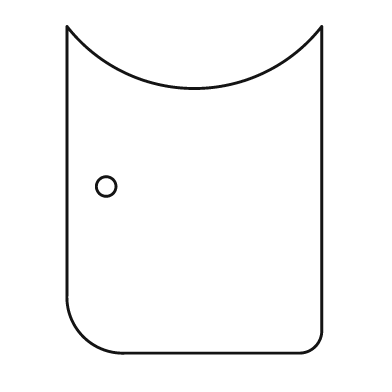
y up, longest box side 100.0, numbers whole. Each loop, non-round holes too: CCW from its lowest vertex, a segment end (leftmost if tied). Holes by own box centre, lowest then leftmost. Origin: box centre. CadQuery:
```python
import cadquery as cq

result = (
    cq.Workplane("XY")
    .moveTo(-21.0, -50.0)
    .lineTo(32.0, -50.0)
    .threePointArc((37.0, -48.0), (39.0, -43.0))
    .lineTo(39.0, 50.0)
    .threePointArc((0.0, 31.0), (-39.0, 50.0))
    .lineTo(-39.0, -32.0)
    .threePointArc((-34.0, -45.0), (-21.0, -50.0))
    .close()
    .moveTo(-27.0, 1.0)
    .circle(3.0)
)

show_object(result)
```